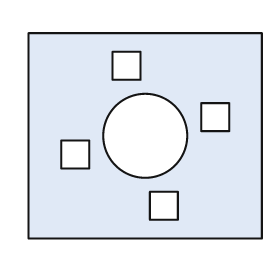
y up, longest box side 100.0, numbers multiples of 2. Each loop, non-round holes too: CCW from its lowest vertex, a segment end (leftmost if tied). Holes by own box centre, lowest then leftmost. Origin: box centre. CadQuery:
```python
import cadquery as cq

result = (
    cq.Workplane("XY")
    .moveTo(-50.0, -44.0)
    .lineTo(50.0, -44.0)
    .lineTo(50.0, 44.0)
    .lineTo(-50.0, 44.0)
    .close()
    .moveTo(2.0, -36.0)
    .lineTo(14.0, -36.0)
    .lineTo(14.0, -24.0)
    .lineTo(2.0, -24.0)
    .close()
    .moveTo(-36.0, -14.0)
    .lineTo(-24.0, -14.0)
    .lineTo(-24.0, -2.0)
    .lineTo(-36.0, -2.0)
    .close()
    .moveTo(0.0, 0.0)
    .circle(18.0)
    .moveTo(24.0, 2.0)
    .lineTo(36.0, 2.0)
    .lineTo(36.0, 14.0)
    .lineTo(24.0, 14.0)
    .close()
    .moveTo(-14.0, 24.0)
    .lineTo(-2.0, 24.0)
    .lineTo(-2.0, 36.0)
    .lineTo(-14.0, 36.0)
    .close()
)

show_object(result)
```